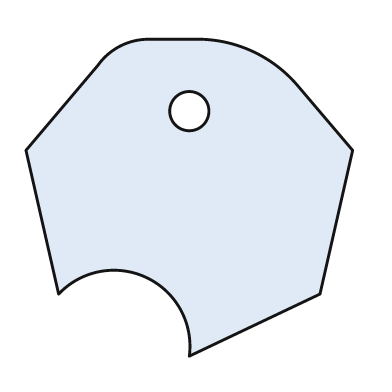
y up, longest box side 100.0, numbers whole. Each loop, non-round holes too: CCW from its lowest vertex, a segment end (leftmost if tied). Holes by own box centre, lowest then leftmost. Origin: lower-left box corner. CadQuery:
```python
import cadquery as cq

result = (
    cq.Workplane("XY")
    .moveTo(50.0, 0.0)
    .lineTo(90.0, 19.0)
    .lineTo(100.0, 63.0)
    .lineTo(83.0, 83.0)
    .threePointArc((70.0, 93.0), (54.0, 97.0))
    .lineTo(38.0, 97.0)
    .threePointArc((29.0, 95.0), (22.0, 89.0))
    .lineTo(0.0, 63.0)
    .lineTo(10.0, 19.0)
    .threePointArc((37.0, 24.0), (50.0, 0.0))
    .close()
    .moveTo(50.0, 75.0)
    .circle(6.0)
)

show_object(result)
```